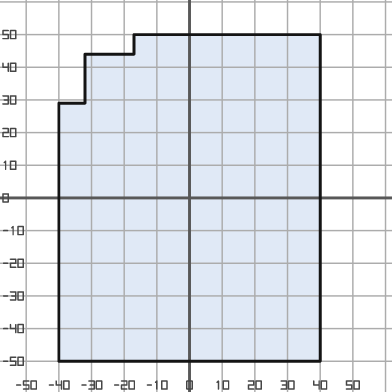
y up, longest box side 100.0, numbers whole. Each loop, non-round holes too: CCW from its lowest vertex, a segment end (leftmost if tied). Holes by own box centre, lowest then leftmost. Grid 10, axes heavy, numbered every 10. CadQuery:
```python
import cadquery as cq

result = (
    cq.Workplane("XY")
    .moveTo(-40.0, -50.0)
    .lineTo(40.0, -50.0)
    .lineTo(40.0, 50.0)
    .lineTo(-17.0, 50.0)
    .lineTo(-17.0, 44.0)
    .lineTo(-32.0, 44.0)
    .lineTo(-32.0, 29.0)
    .lineTo(-40.0, 29.0)
    .close()
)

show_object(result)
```